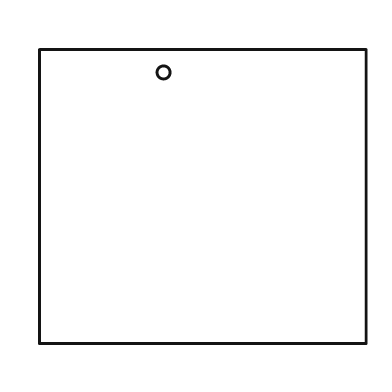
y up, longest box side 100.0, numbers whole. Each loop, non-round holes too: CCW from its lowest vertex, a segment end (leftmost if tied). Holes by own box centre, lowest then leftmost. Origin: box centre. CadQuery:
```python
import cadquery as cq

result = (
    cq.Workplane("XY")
    .moveTo(-50.0, -45.0)
    .lineTo(50.0, -45.0)
    .lineTo(50.0, 45.0)
    .lineTo(-50.0, 45.0)
    .close()
    .moveTo(-12.0, 38.0)
    .circle(2.0)
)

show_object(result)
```